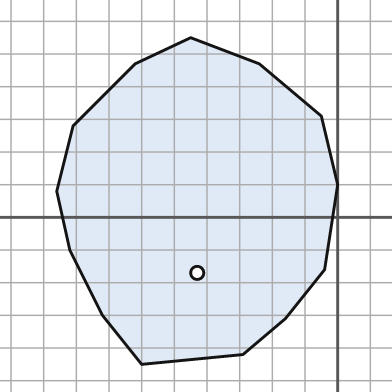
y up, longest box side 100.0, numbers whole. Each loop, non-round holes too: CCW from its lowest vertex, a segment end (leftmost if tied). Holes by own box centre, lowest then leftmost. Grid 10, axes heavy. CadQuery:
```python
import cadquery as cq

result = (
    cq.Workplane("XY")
    .moveTo(-60.0, -45.0)
    .lineTo(-29.0, -42.0)
    .lineTo(-16.0, -31.0)
    .lineTo(-4.0, -16.0)
    .lineTo(0.0, 10.0)
    .lineTo(-5.0, 31.0)
    .lineTo(-24.0, 47.0)
    .lineTo(-45.0, 55.0)
    .lineTo(-62.0, 47.0)
    .lineTo(-81.0, 28.0)
    .lineTo(-86.0, 8.0)
    .lineTo(-82.0, -10.0)
    .lineTo(-72.0, -30.0)
    .close()
    .moveTo(-43.0, -17.0)
    .circle(2.0)
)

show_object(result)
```